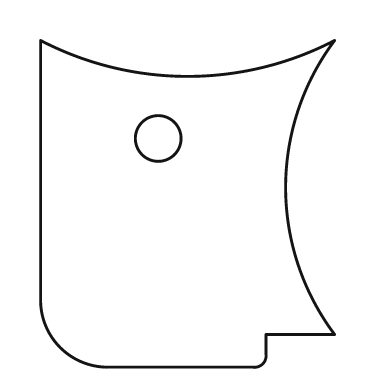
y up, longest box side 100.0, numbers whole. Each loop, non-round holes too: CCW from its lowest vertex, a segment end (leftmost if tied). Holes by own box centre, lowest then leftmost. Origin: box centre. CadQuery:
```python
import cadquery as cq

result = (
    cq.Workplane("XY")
    .moveTo(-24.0, -50.0)
    .lineTo(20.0, -50.0)
    .threePointArc((23.0, -49.0), (24.0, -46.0))
    .lineTo(24.0, -40.0)
    .lineTo(45.0, -40.0)
    .threePointArc((30.0, 5.0), (45.0, 50.0))
    .threePointArc((0.0, 39.0), (-45.0, 50.0))
    .lineTo(-45.0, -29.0)
    .threePointArc((-39.0, -44.0), (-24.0, -50.0))
    .close()
    .moveTo(-9.0, 20.0)
    .circle(7.0)
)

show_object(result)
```